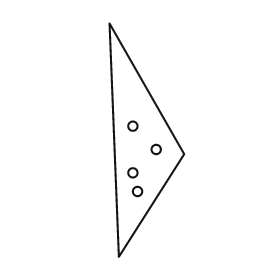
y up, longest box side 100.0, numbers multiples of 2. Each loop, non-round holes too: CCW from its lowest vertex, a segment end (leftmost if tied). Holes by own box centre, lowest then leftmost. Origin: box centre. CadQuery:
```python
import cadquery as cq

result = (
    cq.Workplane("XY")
    .moveTo(-12.0, -50.0)
    .lineTo(16.0, -6.0)
    .lineTo(-16.0, 50.0)
    .close()
    .moveTo(-4.0, -22.0)
    .circle(2.0)
    .moveTo(-6.0, -14.0)
    .circle(2.0)
    .moveTo(4.0, -4.0)
    .circle(2.0)
    .moveTo(-6.0, 6.0)
    .circle(2.0)
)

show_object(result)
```